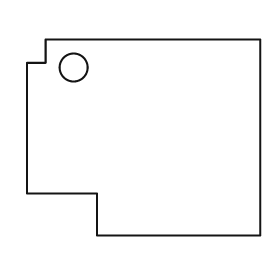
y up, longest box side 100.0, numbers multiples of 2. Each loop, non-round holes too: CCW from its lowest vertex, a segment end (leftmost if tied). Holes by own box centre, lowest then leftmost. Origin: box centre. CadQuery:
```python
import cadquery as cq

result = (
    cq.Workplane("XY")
    .moveTo(-20.0, -42.0)
    .lineTo(50.0, -42.0)
    .lineTo(50.0, 42.0)
    .lineTo(-42.0, 42.0)
    .lineTo(-42.0, 32.0)
    .lineTo(-50.0, 32.0)
    .lineTo(-50.0, -24.0)
    .lineTo(-20.0, -24.0)
    .close()
    .moveTo(-30.0, 30.0)
    .circle(6.0)
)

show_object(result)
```